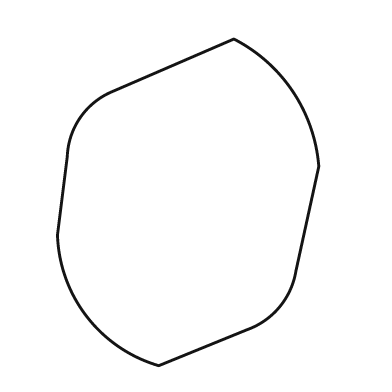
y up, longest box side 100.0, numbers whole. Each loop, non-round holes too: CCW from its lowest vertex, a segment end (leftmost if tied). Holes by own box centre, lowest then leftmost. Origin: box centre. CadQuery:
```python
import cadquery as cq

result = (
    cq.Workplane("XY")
    .moveTo(-9.0, -50.0)
    .lineTo(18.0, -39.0)
    .threePointArc((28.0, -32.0), (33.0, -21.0))
    .lineTo(40.0, 11.0)
    .threePointArc((32.0, 34.0), (14.0, 50.0))
    .lineTo(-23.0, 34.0)
    .threePointArc((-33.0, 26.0), (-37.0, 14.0))
    .lineTo(-40.0, -10.0)
    .threePointArc((-31.0, -35.0), (-9.0, -50.0))
    .close()
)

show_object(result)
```